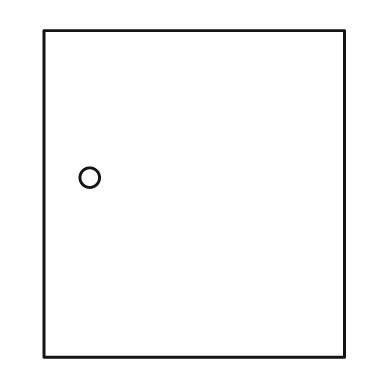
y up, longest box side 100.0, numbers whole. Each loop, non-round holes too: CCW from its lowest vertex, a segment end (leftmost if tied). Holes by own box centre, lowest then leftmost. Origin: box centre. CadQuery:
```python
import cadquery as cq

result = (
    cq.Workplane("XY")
    .moveTo(-46.0, -50.0)
    .lineTo(46.0, -50.0)
    .lineTo(46.0, 50.0)
    .lineTo(-46.0, 50.0)
    .close()
    .moveTo(-32.0, 5.0)
    .circle(3.0)
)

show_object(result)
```